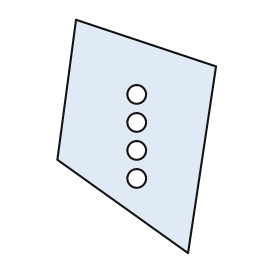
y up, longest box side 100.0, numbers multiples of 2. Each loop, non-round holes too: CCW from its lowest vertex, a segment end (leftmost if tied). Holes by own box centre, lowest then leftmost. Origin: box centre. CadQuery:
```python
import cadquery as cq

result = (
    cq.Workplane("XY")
    .moveTo(22.0, -50.0)
    .lineTo(34.0, 30.0)
    .lineTo(-26.0, 50.0)
    .lineTo(-34.0, -10.0)
    .close()
    .moveTo(0.0, -18.0)
    .circle(4.0)
    .moveTo(0.0, -6.0)
    .circle(4.0)
    .moveTo(0.0, 6.0)
    .circle(4.0)
    .moveTo(0.0, 18.0)
    .circle(4.0)
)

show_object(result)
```